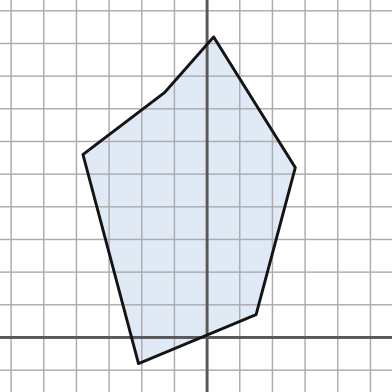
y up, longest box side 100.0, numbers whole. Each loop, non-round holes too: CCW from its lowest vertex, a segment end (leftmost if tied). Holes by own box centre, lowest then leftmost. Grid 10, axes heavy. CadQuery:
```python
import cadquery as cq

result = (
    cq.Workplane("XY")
    .moveTo(-21.0, -8.0)
    .lineTo(15.0, 7.0)
    .lineTo(27.0, 52.0)
    .lineTo(2.0, 92.0)
    .lineTo(-13.0, 75.0)
    .lineTo(-38.0, 56.0)
    .close()
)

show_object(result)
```